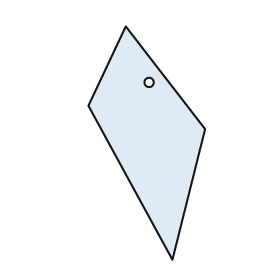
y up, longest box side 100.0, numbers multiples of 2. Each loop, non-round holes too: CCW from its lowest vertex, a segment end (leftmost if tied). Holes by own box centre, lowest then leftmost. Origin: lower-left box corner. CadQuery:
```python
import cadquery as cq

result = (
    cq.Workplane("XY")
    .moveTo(36.0, 0.0)
    .lineTo(50.0, 56.0)
    .lineTo(16.0, 100.0)
    .lineTo(0.0, 66.0)
    .close()
    .moveTo(26.0, 76.0)
    .circle(2.0)
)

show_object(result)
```